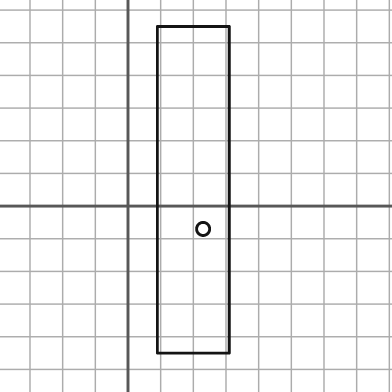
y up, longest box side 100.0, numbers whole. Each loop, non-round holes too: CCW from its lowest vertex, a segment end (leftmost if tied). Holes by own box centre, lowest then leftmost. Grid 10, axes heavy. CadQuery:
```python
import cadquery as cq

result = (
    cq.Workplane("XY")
    .moveTo(9.0, -45.0)
    .lineTo(31.0, -45.0)
    .lineTo(31.0, 55.0)
    .lineTo(9.0, 55.0)
    .close()
    .moveTo(23.0, -7.0)
    .circle(2.0)
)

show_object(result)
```